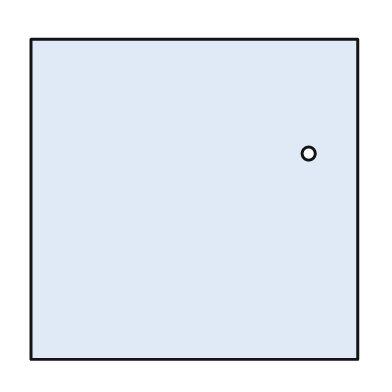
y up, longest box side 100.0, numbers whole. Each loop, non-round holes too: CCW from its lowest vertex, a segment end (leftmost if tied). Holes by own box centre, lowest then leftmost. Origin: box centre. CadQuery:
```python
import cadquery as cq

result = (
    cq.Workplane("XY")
    .moveTo(-50.0, -49.0)
    .lineTo(50.0, -49.0)
    .lineTo(50.0, 49.0)
    .lineTo(-50.0, 49.0)
    .close()
    .moveTo(35.0, 14.0)
    .circle(2.0)
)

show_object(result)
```